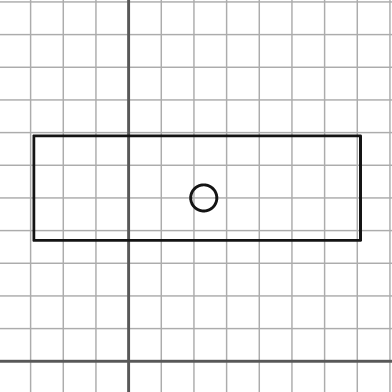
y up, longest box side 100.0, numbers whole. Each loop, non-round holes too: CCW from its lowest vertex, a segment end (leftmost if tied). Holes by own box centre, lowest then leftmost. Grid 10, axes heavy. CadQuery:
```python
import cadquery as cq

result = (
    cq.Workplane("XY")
    .moveTo(-29.0, 37.0)
    .lineTo(71.0, 37.0)
    .lineTo(71.0, 69.0)
    .lineTo(-29.0, 69.0)
    .close()
    .moveTo(23.0, 50.0)
    .circle(4.0)
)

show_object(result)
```